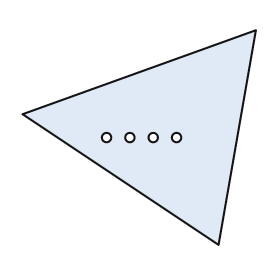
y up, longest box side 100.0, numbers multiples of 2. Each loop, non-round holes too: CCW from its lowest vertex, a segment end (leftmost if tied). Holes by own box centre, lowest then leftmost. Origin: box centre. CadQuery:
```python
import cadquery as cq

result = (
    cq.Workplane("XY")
    .moveTo(34.0, -46.0)
    .lineTo(50.0, 46.0)
    .lineTo(-50.0, 10.0)
    .close()
    .moveTo(-14.0, 0.0)
    .circle(2.0)
    .moveTo(-4.0, 0.0)
    .circle(2.0)
    .moveTo(6.0, 0.0)
    .circle(2.0)
    .moveTo(16.0, 0.0)
    .circle(2.0)
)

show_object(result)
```